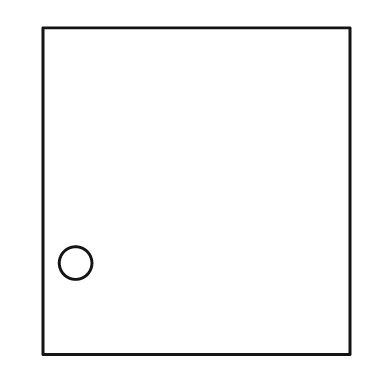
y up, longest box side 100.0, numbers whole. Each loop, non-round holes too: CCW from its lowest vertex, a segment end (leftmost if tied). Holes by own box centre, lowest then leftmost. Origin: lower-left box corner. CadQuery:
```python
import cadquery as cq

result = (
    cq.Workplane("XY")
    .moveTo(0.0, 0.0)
    .lineTo(94.0, 0.0)
    .lineTo(94.0, 100.0)
    .lineTo(0.0, 100.0)
    .close()
    .moveTo(10.0, 28.0)
    .circle(5.0)
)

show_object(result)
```